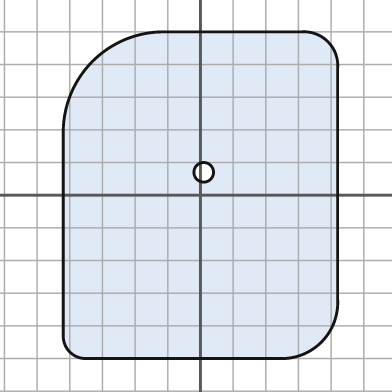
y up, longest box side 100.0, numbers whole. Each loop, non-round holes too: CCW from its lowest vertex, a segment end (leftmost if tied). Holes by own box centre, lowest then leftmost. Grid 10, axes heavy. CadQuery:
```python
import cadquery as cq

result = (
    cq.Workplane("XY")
    .moveTo(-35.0, -50.0)
    .lineTo(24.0, -50.0)
    .threePointArc((37.0, -45.0), (42.0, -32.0))
    .lineTo(42.0, 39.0)
    .threePointArc((39.0, 47.0), (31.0, 50.0))
    .lineTo(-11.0, 50.0)
    .threePointArc((-33.0, 41.0), (-42.0, 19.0))
    .lineTo(-42.0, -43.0)
    .threePointArc((-40.0, -48.0), (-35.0, -50.0))
    .close()
    .moveTo(1.0, 7.0)
    .circle(3.0)
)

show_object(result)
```